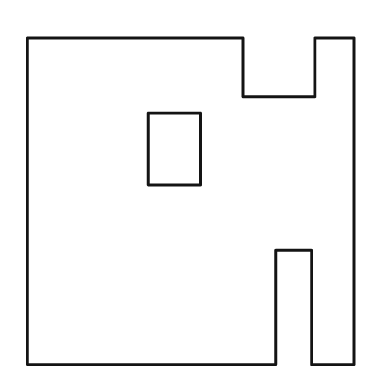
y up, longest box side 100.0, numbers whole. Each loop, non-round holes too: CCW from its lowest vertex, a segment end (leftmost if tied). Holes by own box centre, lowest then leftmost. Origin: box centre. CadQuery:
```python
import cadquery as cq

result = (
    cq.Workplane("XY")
    .moveTo(-50.0, -50.0)
    .lineTo(26.0, -50.0)
    .lineTo(26.0, -15.0)
    .lineTo(37.0, -15.0)
    .lineTo(37.0, -50.0)
    .lineTo(50.0, -50.0)
    .lineTo(50.0, 50.0)
    .lineTo(38.0, 50.0)
    .lineTo(38.0, 32.0)
    .lineTo(16.0, 32.0)
    .lineTo(16.0, 50.0)
    .lineTo(-50.0, 50.0)
    .close()
    .moveTo(-13.0, 5.0)
    .lineTo(3.0, 5.0)
    .lineTo(3.0, 27.0)
    .lineTo(-13.0, 27.0)
    .close()
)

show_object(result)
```